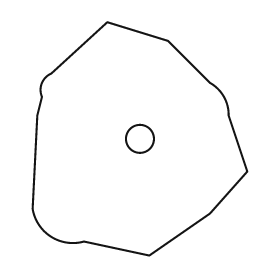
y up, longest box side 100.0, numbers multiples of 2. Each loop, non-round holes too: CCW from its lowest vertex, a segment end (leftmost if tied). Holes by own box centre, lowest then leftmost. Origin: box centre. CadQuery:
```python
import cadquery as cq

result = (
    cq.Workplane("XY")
    .moveTo(4.0, -50.0)
    .lineTo(30.0, -32.0)
    .lineTo(46.0, -14.0)
    .lineTo(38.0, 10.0)
    .threePointArc((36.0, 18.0), (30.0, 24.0))
    .lineTo(12.0, 42.0)
    .lineTo(-14.0, 50.0)
    .lineTo(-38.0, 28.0)
    .threePointArc((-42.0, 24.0), (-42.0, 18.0))
    .lineTo(-44.0, 10.0)
    .lineTo(-46.0, -30.0)
    .threePointArc((-38.0, -42.0), (-24.0, -44.0))
    .close()
    .moveTo(0.0, 0.0)
    .circle(6.0)
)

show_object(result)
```